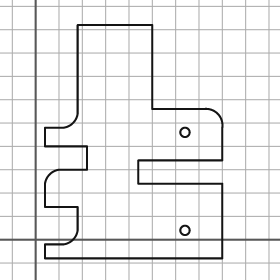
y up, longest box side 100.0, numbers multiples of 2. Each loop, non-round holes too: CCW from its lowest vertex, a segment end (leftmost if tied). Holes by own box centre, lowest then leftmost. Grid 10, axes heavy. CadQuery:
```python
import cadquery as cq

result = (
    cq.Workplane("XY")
    .moveTo(4.0, -8.0)
    .lineTo(80.0, -8.0)
    .lineTo(80.0, 24.0)
    .lineTo(44.0, 24.0)
    .lineTo(44.0, 34.0)
    .lineTo(80.0, 34.0)
    .lineTo(80.0, 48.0)
    .threePointArc((78.0, 54.0), (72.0, 56.0))
    .lineTo(50.0, 56.0)
    .lineTo(50.0, 92.0)
    .lineTo(18.0, 92.0)
    .lineTo(18.0, 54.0)
    .threePointArc((16.0, 50.0), (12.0, 48.0))
    .lineTo(4.0, 48.0)
    .lineTo(4.0, 40.0)
    .lineTo(22.0, 40.0)
    .lineTo(22.0, 30.0)
    .lineTo(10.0, 30.0)
    .threePointArc((6.0, 28.0), (4.0, 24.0))
    .lineTo(4.0, 14.0)
    .lineTo(18.0, 14.0)
    .lineTo(18.0, 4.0)
    .threePointArc((16.0, 0.0), (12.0, -2.0))
    .lineTo(4.0, -2.0)
    .close()
    .moveTo(64.0, 4.0)
    .circle(2.0)
    .moveTo(64.0, 46.0)
    .circle(2.0)
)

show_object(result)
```